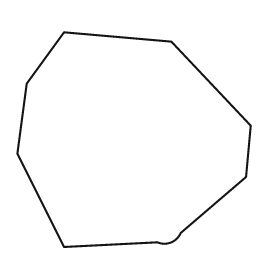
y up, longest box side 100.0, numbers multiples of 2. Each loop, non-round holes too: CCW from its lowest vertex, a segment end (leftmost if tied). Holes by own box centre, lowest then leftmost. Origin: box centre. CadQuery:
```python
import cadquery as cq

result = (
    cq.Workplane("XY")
    .moveTo(-30.0, -46.0)
    .lineTo(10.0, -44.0)
    .threePointArc((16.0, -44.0), (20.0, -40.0))
    .lineTo(48.0, -16.0)
    .lineTo(50.0, 6.0)
    .lineTo(16.0, 42.0)
    .lineTo(-30.0, 46.0)
    .lineTo(-46.0, 24.0)
    .lineTo(-50.0, -6.0)
    .close()
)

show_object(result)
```